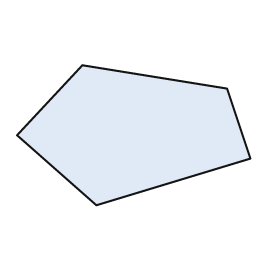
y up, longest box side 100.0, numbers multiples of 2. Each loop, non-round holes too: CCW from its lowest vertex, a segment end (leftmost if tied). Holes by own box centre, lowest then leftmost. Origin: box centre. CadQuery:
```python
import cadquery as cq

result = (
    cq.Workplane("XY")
    .moveTo(-16.0, -30.0)
    .lineTo(50.0, -10.0)
    .lineTo(40.0, 20.0)
    .lineTo(-22.0, 30.0)
    .lineTo(-50.0, 0.0)
    .close()
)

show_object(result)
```